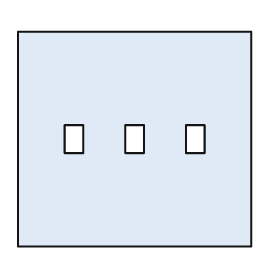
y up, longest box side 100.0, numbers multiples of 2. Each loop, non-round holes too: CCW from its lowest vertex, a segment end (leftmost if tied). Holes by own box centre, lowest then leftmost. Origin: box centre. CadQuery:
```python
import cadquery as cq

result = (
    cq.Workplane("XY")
    .moveTo(-50.0, -46.0)
    .lineTo(50.0, -46.0)
    .lineTo(50.0, 46.0)
    .lineTo(-50.0, 46.0)
    .close()
    .moveTo(-30.0, -6.0)
    .lineTo(-22.0, -6.0)
    .lineTo(-22.0, 6.0)
    .lineTo(-30.0, 6.0)
    .close()
    .moveTo(-4.0, -6.0)
    .lineTo(4.0, -6.0)
    .lineTo(4.0, 6.0)
    .lineTo(-4.0, 6.0)
    .close()
    .moveTo(22.0, -6.0)
    .lineTo(30.0, -6.0)
    .lineTo(30.0, 6.0)
    .lineTo(22.0, 6.0)
    .close()
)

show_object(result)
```